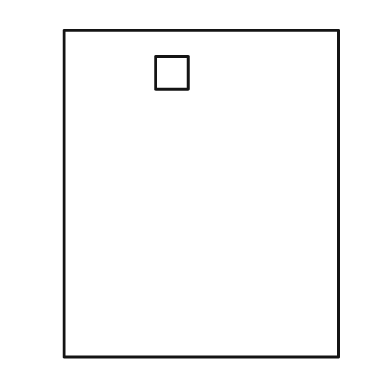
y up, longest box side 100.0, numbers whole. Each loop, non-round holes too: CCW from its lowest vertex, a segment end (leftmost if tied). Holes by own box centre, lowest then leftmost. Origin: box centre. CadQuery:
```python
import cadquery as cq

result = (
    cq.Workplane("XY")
    .moveTo(-42.0, -50.0)
    .lineTo(42.0, -50.0)
    .lineTo(42.0, 50.0)
    .lineTo(-42.0, 50.0)
    .close()
    .moveTo(-14.0, 32.0)
    .lineTo(-4.0, 32.0)
    .lineTo(-4.0, 42.0)
    .lineTo(-14.0, 42.0)
    .close()
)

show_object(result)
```